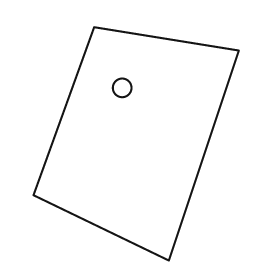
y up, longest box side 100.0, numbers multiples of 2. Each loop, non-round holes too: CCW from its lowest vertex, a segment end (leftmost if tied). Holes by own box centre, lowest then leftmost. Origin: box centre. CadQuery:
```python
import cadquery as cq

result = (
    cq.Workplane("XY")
    .moveTo(14.0, -50.0)
    .lineTo(44.0, 40.0)
    .lineTo(-18.0, 50.0)
    .lineTo(-44.0, -22.0)
    .close()
    .moveTo(-6.0, 24.0)
    .circle(4.0)
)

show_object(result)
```